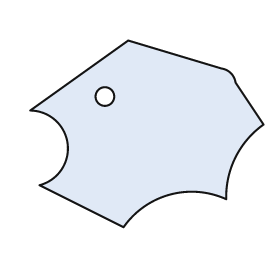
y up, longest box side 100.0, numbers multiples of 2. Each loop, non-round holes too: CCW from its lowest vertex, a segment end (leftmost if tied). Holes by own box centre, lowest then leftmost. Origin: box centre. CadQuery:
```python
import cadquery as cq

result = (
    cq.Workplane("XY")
    .moveTo(-10.0, -40.0)
    .threePointArc((10.0, -26.0), (34.0, -28.0))
    .threePointArc((38.0, -10.0), (50.0, 4.0))
    .lineTo(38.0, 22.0)
    .threePointArc((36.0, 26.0), (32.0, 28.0))
    .lineTo(-8.0, 40.0)
    .lineTo(-50.0, 10.0)
    .threePointArc((-34.0, -4.0), (-46.0, -22.0))
    .close()
    .moveTo(-18.0, 16.0)
    .circle(4.0)
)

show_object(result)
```